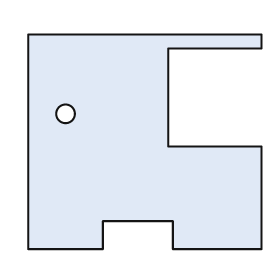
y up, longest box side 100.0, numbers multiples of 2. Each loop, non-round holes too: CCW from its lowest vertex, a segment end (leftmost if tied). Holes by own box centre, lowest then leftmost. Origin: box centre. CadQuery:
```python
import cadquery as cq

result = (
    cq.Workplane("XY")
    .moveTo(-50.0, -46.0)
    .lineTo(-18.0, -46.0)
    .lineTo(-18.0, -34.0)
    .lineTo(12.0, -34.0)
    .lineTo(12.0, -46.0)
    .lineTo(50.0, -46.0)
    .lineTo(50.0, -2.0)
    .lineTo(10.0, -2.0)
    .lineTo(10.0, 40.0)
    .lineTo(50.0, 40.0)
    .lineTo(50.0, 46.0)
    .lineTo(-50.0, 46.0)
    .close()
    .moveTo(-34.0, 12.0)
    .circle(4.0)
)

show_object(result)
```